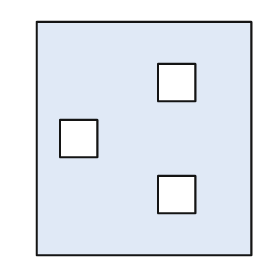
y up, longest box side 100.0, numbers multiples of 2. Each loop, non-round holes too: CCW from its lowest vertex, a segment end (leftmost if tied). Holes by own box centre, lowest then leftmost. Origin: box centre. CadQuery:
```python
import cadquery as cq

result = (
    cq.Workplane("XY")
    .moveTo(-46.0, -50.0)
    .lineTo(46.0, -50.0)
    .lineTo(46.0, 50.0)
    .lineTo(-46.0, 50.0)
    .close()
    .moveTo(6.0, -32.0)
    .lineTo(22.0, -32.0)
    .lineTo(22.0, -16.0)
    .lineTo(6.0, -16.0)
    .close()
    .moveTo(-36.0, -8.0)
    .lineTo(-20.0, -8.0)
    .lineTo(-20.0, 8.0)
    .lineTo(-36.0, 8.0)
    .close()
    .moveTo(6.0, 16.0)
    .lineTo(22.0, 16.0)
    .lineTo(22.0, 32.0)
    .lineTo(6.0, 32.0)
    .close()
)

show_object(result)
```